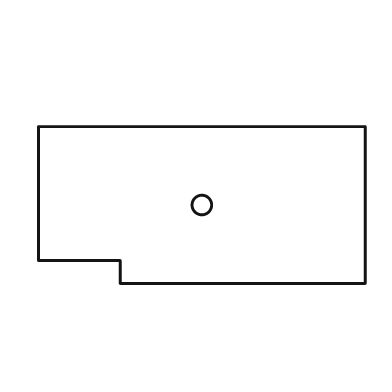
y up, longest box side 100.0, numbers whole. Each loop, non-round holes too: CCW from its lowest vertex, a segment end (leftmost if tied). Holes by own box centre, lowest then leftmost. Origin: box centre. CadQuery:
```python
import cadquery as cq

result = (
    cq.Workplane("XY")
    .moveTo(-25.0, -24.0)
    .lineTo(50.0, -24.0)
    .lineTo(50.0, 24.0)
    .lineTo(-50.0, 24.0)
    .lineTo(-50.0, -17.0)
    .lineTo(-25.0, -17.0)
    .close()
    .moveTo(0.0, 0.0)
    .circle(3.0)
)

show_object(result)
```